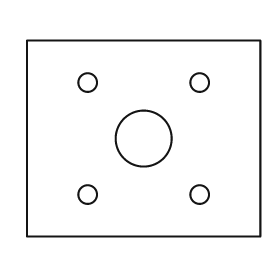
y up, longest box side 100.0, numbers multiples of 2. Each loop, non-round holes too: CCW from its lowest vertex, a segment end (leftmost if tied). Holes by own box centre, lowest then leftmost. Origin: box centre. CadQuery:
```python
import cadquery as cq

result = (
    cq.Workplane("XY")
    .moveTo(-50.0, -42.0)
    .lineTo(50.0, -42.0)
    .lineTo(50.0, 42.0)
    .lineTo(-50.0, 42.0)
    .close()
    .moveTo(-24.0, -24.0)
    .circle(4.0)
    .moveTo(24.0, -24.0)
    .circle(4.0)
    .moveTo(0.0, 0.0)
    .circle(12.0)
    .moveTo(-24.0, 24.0)
    .circle(4.0)
    .moveTo(24.0, 24.0)
    .circle(4.0)
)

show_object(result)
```